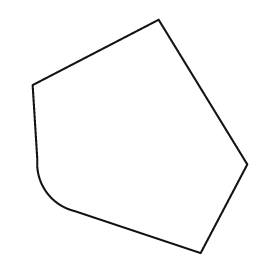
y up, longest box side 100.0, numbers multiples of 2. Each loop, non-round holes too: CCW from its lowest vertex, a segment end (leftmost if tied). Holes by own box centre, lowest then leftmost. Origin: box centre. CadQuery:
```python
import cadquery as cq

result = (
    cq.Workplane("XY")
    .moveTo(26.0, -50.0)
    .lineTo(46.0, -12.0)
    .lineTo(8.0, 50.0)
    .lineTo(-46.0, 22.0)
    .lineTo(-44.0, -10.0)
    .threePointArc((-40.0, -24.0), (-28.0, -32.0))
    .close()
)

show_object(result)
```